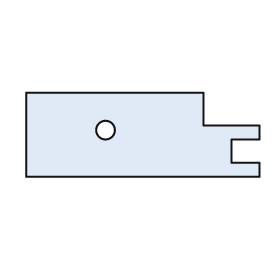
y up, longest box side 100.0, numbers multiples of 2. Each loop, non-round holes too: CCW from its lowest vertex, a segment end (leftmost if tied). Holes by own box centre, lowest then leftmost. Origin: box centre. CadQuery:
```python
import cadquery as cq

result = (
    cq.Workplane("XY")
    .moveTo(-50.0, -18.0)
    .lineTo(50.0, -18.0)
    .lineTo(50.0, -12.0)
    .lineTo(38.0, -12.0)
    .lineTo(38.0, -2.0)
    .lineTo(50.0, -2.0)
    .lineTo(50.0, 4.0)
    .lineTo(26.0, 4.0)
    .lineTo(26.0, 18.0)
    .lineTo(-50.0, 18.0)
    .close()
    .moveTo(-16.0, 2.0)
    .circle(4.0)
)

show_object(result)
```